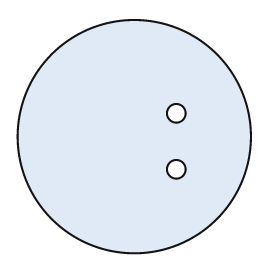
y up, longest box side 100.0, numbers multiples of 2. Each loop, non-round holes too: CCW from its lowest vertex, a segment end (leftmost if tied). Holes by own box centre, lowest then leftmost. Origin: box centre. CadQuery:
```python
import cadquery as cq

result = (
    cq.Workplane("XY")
    .moveTo(0.0, 0.0)
    .circle(50.0)
    .moveTo(18.0, -14.0)
    .circle(4.0)
    .moveTo(18.0, 10.0)
    .circle(4.0)
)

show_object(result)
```